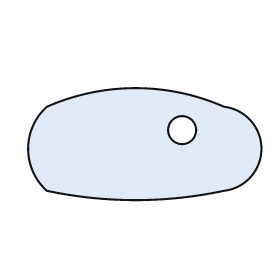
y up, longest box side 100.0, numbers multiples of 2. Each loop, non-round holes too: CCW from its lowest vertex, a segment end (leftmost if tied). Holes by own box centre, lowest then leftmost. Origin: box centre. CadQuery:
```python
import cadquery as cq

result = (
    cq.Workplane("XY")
    .moveTo(-42.0, -20.0)
    .threePointArc((-4.0, -24.0), (34.0, -20.0))
    .threePointArc((50.0, -2.0), (34.0, 16.0))
    .threePointArc((-4.0, 24.0), (-42.0, 16.0))
    .threePointArc((-50.0, -2.0), (-42.0, -20.0))
    .close()
    .moveTo(16.0, 6.0)
    .circle(6.0)
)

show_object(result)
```